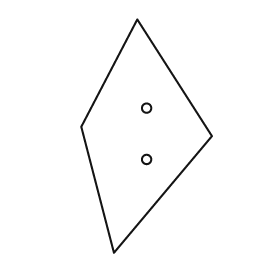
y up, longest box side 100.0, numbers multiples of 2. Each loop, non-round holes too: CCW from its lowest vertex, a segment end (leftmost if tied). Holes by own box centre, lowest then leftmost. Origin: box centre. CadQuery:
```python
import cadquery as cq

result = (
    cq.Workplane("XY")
    .moveTo(-14.0, -50.0)
    .lineTo(28.0, 0.0)
    .lineTo(-4.0, 50.0)
    .lineTo(-28.0, 4.0)
    .close()
    .moveTo(0.0, -10.0)
    .circle(2.0)
    .moveTo(0.0, 12.0)
    .circle(2.0)
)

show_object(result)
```